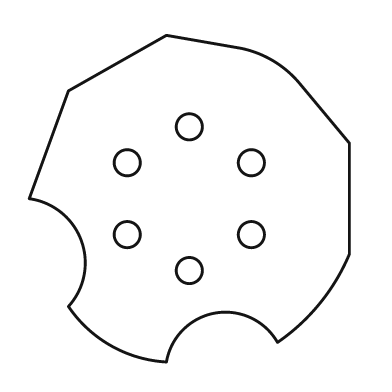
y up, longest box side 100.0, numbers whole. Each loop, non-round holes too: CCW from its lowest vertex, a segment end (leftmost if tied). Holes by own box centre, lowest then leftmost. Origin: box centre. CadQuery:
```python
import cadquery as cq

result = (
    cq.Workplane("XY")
    .moveTo(-7.0, -50.0)
    .threePointArc((8.0, -35.0), (27.0, -44.0))
    .threePointArc((40.0, -32.0), (49.0, -17.0))
    .lineTo(49.0, 17.0)
    .lineTo(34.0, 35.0)
    .threePointArc((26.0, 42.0), (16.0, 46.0))
    .lineTo(-7.0, 50.0)
    .lineTo(-37.0, 33.0)
    .lineTo(-49.0, 0.0)
    .threePointArc((-33.0, -13.0), (-37.0, -33.0))
    .threePointArc((-24.0, -45.0), (-7.0, -50.0))
    .close()
    .moveTo(0.0, -22.0)
    .circle(4.0)
    .moveTo(-19.0, -11.0)
    .circle(4.0)
    .moveTo(19.0, -11.0)
    .circle(4.0)
    .moveTo(-19.0, 11.0)
    .circle(4.0)
    .moveTo(19.0, 11.0)
    .circle(4.0)
    .moveTo(0.0, 22.0)
    .circle(4.0)
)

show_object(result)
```